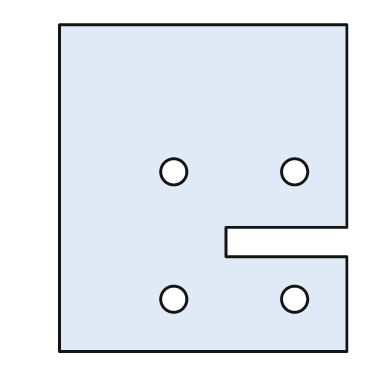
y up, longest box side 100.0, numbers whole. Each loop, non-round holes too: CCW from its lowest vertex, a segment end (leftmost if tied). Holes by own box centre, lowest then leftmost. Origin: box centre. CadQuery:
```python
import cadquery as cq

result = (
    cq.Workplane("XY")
    .moveTo(-44.0, -50.0)
    .lineTo(44.0, -50.0)
    .lineTo(44.0, -21.0)
    .lineTo(7.0, -21.0)
    .lineTo(7.0, -12.0)
    .lineTo(44.0, -12.0)
    .lineTo(44.0, 50.0)
    .lineTo(-44.0, 50.0)
    .close()
    .moveTo(-9.0, -34.0)
    .circle(4.0)
    .moveTo(28.0, -34.0)
    .circle(4.0)
    .moveTo(-9.0, 5.0)
    .circle(4.0)
    .moveTo(28.0, 5.0)
    .circle(4.0)
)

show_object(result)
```